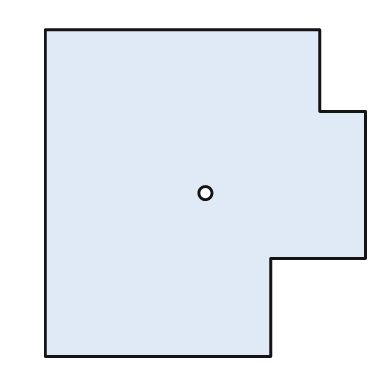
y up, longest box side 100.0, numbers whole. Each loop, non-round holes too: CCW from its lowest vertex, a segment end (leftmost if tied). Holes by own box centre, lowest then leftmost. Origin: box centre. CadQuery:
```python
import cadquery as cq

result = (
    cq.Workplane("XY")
    .moveTo(-49.0, -50.0)
    .lineTo(20.0, -50.0)
    .lineTo(20.0, -20.0)
    .lineTo(49.0, -20.0)
    .lineTo(49.0, 25.0)
    .lineTo(35.0, 25.0)
    .lineTo(35.0, 50.0)
    .lineTo(-49.0, 50.0)
    .close()
    .moveTo(0.0, 0.0)
    .circle(2.0)
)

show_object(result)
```